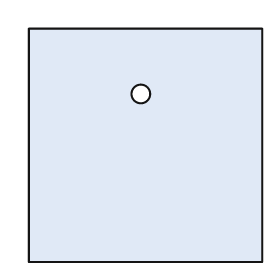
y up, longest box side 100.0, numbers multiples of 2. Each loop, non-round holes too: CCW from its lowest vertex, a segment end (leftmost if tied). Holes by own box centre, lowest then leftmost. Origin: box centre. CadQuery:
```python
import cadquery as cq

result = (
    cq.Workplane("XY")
    .moveTo(-50.0, -50.0)
    .lineTo(50.0, -50.0)
    .lineTo(50.0, 50.0)
    .lineTo(-50.0, 50.0)
    .close()
    .moveTo(-2.0, 22.0)
    .circle(4.0)
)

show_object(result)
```